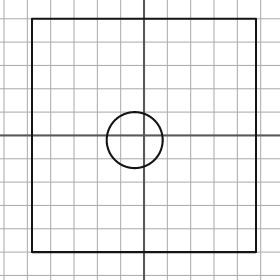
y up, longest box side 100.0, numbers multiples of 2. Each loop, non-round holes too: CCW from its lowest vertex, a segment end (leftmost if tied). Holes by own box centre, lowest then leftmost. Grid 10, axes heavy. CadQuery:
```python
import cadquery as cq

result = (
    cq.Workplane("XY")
    .moveTo(-48.0, -50.0)
    .lineTo(48.0, -50.0)
    .lineTo(48.0, 50.0)
    .lineTo(-48.0, 50.0)
    .close()
    .moveTo(-4.0, -2.0)
    .circle(12.0)
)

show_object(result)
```